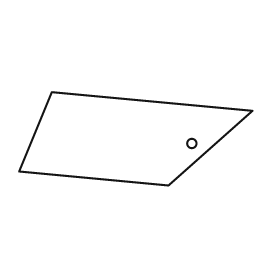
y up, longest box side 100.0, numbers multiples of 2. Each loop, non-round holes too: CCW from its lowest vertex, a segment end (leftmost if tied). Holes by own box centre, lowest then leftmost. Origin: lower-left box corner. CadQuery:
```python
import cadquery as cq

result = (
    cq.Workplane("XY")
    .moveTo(64.0, 0.0)
    .lineTo(100.0, 32.0)
    .lineTo(14.0, 40.0)
    .lineTo(0.0, 6.0)
    .close()
    .moveTo(74.0, 18.0)
    .circle(2.0)
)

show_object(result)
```